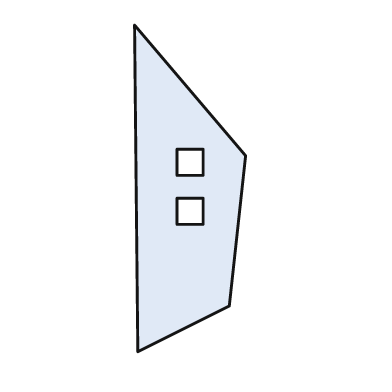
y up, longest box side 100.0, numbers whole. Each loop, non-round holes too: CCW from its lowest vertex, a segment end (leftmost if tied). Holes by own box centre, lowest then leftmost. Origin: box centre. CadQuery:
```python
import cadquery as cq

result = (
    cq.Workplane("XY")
    .moveTo(-16.0, -50.0)
    .lineTo(12.0, -36.0)
    .lineTo(17.0, 10.0)
    .lineTo(-17.0, 50.0)
    .close()
    .moveTo(-4.0, -11.0)
    .lineTo(4.0, -11.0)
    .lineTo(4.0, -3.0)
    .lineTo(-4.0, -3.0)
    .close()
    .moveTo(-4.0, 4.0)
    .lineTo(4.0, 4.0)
    .lineTo(4.0, 12.0)
    .lineTo(-4.0, 12.0)
    .close()
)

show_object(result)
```